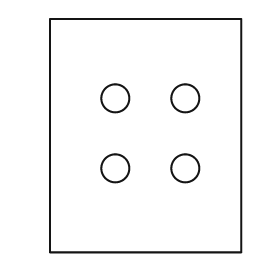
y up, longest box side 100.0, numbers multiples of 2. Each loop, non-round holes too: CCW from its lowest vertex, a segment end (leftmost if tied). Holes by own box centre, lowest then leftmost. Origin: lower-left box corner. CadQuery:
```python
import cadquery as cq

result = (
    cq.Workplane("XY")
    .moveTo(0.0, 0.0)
    .lineTo(82.0, 0.0)
    .lineTo(82.0, 100.0)
    .lineTo(0.0, 100.0)
    .close()
    .moveTo(28.0, 36.0)
    .circle(6.0)
    .moveTo(58.0, 36.0)
    .circle(6.0)
    .moveTo(28.0, 66.0)
    .circle(6.0)
    .moveTo(58.0, 66.0)
    .circle(6.0)
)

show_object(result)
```